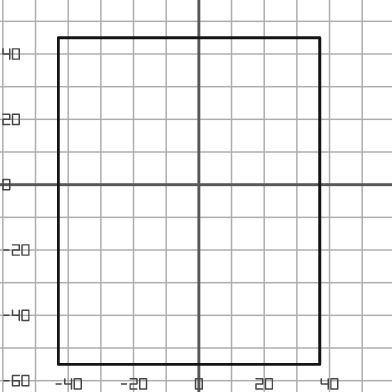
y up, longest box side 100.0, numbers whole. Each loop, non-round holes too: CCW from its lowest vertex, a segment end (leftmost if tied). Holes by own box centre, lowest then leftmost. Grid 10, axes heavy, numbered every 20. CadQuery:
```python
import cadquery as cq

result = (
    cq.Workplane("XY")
    .moveTo(-43.0, -55.0)
    .lineTo(37.0, -55.0)
    .lineTo(37.0, 45.0)
    .lineTo(-43.0, 45.0)
    .close()
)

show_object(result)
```